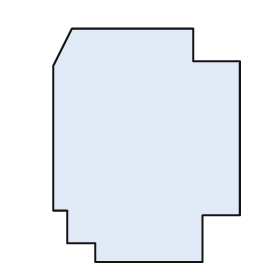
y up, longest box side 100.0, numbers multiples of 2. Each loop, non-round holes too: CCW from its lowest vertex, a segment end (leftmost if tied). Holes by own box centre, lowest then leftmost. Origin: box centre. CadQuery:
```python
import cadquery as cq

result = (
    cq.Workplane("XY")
    .moveTo(-22.0, -50.0)
    .lineTo(24.0, -50.0)
    .lineTo(24.0, -30.0)
    .lineTo(40.0, -30.0)
    .lineTo(40.0, 36.0)
    .lineTo(20.0, 36.0)
    .lineTo(20.0, 50.0)
    .lineTo(-32.0, 50.0)
    .lineTo(-40.0, 34.0)
    .lineTo(-40.0, -28.0)
    .lineTo(-34.0, -28.0)
    .lineTo(-34.0, -42.0)
    .lineTo(-22.0, -42.0)
    .close()
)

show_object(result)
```